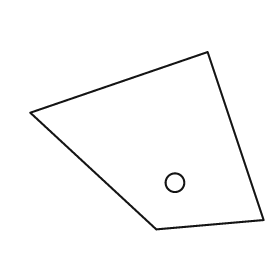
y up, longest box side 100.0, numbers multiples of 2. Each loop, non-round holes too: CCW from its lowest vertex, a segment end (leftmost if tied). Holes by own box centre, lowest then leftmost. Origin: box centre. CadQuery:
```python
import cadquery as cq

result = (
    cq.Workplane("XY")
    .moveTo(4.0, -38.0)
    .lineTo(50.0, -34.0)
    .lineTo(26.0, 38.0)
    .lineTo(-50.0, 12.0)
    .close()
    .moveTo(12.0, -18.0)
    .circle(4.0)
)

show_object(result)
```